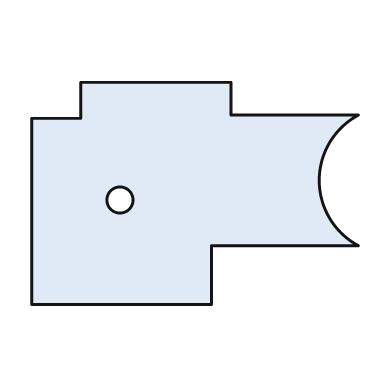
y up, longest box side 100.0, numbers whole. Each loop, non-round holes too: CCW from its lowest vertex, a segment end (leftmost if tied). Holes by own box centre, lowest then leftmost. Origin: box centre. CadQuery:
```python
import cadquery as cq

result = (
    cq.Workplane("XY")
    .moveTo(-50.0, -34.0)
    .lineTo(5.0, -34.0)
    .lineTo(5.0, -16.0)
    .lineTo(50.0, -16.0)
    .threePointArc((38.0, 4.0), (50.0, 24.0))
    .lineTo(11.0, 24.0)
    .lineTo(11.0, 34.0)
    .lineTo(-35.0, 34.0)
    .lineTo(-35.0, 23.0)
    .lineTo(-50.0, 23.0)
    .close()
    .moveTo(-23.0, -2.0)
    .circle(4.0)
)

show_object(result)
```